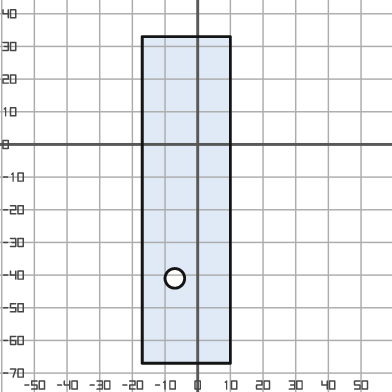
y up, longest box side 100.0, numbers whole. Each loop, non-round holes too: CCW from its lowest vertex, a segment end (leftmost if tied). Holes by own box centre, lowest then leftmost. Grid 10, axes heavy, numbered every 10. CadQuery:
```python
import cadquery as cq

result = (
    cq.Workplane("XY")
    .moveTo(-17.0, -67.0)
    .lineTo(10.0, -67.0)
    .lineTo(10.0, 33.0)
    .lineTo(-17.0, 33.0)
    .close()
    .moveTo(-7.0, -41.0)
    .circle(3.0)
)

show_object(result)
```